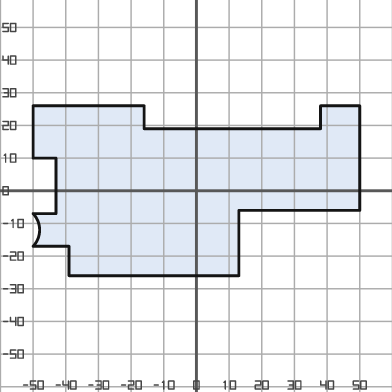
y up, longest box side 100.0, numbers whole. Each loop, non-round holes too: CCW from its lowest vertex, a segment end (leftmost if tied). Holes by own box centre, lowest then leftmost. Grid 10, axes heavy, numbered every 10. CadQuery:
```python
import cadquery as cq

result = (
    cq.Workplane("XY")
    .moveTo(-39.0, -26.0)
    .lineTo(13.0, -26.0)
    .lineTo(13.0, -6.0)
    .lineTo(50.0, -6.0)
    .lineTo(50.0, 26.0)
    .lineTo(38.0, 26.0)
    .lineTo(38.0, 19.0)
    .lineTo(-16.0, 19.0)
    .lineTo(-16.0, 26.0)
    .lineTo(-50.0, 26.0)
    .lineTo(-50.0, 10.0)
    .lineTo(-43.0, 10.0)
    .lineTo(-43.0, -7.0)
    .lineTo(-50.0, -7.0)
    .threePointArc((-48.0, -12.0), (-50.0, -17.0))
    .lineTo(-39.0, -17.0)
    .close()
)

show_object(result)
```